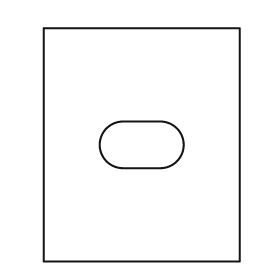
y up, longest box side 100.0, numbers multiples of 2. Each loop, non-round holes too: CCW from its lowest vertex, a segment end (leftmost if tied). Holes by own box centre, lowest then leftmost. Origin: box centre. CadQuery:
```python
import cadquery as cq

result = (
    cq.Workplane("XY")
    .moveTo(-42.0, -50.0)
    .lineTo(42.0, -50.0)
    .lineTo(42.0, 50.0)
    .lineTo(-42.0, 50.0)
    .close()
    .moveTo(-8.0, -10.0)
    .lineTo(8.0, -10.0)
    .threePointArc((18.0, 0.0), (8.0, 10.0))
    .lineTo(-8.0, 10.0)
    .threePointArc((-18.0, 0.0), (-8.0, -10.0))
    .close()
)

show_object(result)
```